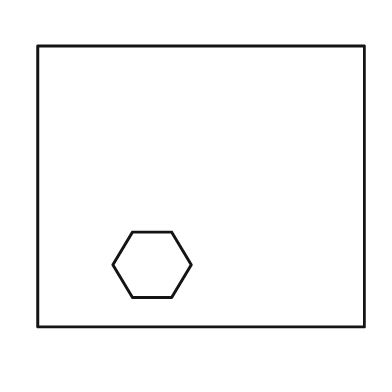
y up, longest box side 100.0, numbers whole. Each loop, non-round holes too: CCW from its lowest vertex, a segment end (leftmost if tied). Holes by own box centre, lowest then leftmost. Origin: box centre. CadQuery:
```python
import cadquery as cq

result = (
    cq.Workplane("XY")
    .moveTo(-50.0, -43.0)
    .lineTo(50.0, -43.0)
    .lineTo(50.0, 43.0)
    .lineTo(-50.0, 43.0)
    .close()
    .moveTo(-21.0, -34.0)
    .lineTo(-9.0, -34.0)
    .lineTo(-3.0, -24.0)
    .lineTo(-9.0, -14.0)
    .lineTo(-21.0, -14.0)
    .lineTo(-27.0, -24.0)
    .close()
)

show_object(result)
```